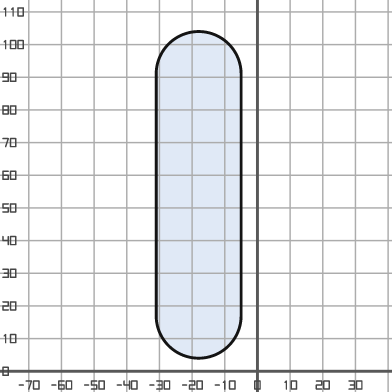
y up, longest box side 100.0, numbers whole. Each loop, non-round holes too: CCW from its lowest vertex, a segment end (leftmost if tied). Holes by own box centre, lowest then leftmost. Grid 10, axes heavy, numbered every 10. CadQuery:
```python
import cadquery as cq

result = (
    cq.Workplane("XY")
    .moveTo(-31.0, 17.0)
    .threePointArc((-18.0, 4.0), (-5.0, 17.0))
    .lineTo(-5.0, 91.0)
    .threePointArc((-18.0, 104.0), (-31.0, 91.0))
    .close()
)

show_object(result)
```